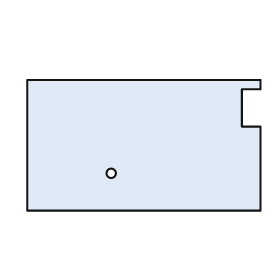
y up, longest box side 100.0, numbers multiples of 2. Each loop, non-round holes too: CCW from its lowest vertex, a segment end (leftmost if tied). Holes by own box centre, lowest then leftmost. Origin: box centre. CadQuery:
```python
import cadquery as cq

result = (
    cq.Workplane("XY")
    .moveTo(-50.0, -28.0)
    .lineTo(50.0, -28.0)
    .lineTo(50.0, 8.0)
    .lineTo(42.0, 8.0)
    .lineTo(42.0, 24.0)
    .lineTo(50.0, 24.0)
    .lineTo(50.0, 28.0)
    .lineTo(-50.0, 28.0)
    .close()
    .moveTo(-14.0, -12.0)
    .circle(2.0)
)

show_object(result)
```